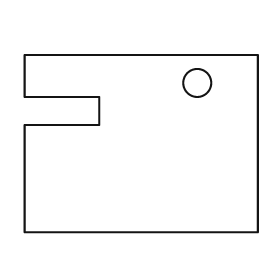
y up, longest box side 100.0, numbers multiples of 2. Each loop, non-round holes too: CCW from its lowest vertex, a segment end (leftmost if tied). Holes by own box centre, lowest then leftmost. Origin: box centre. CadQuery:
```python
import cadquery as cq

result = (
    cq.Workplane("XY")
    .moveTo(-50.0, -38.0)
    .lineTo(50.0, -38.0)
    .lineTo(50.0, 38.0)
    .lineTo(-50.0, 38.0)
    .lineTo(-50.0, 20.0)
    .lineTo(-18.0, 20.0)
    .lineTo(-18.0, 8.0)
    .lineTo(-50.0, 8.0)
    .close()
    .moveTo(24.0, 26.0)
    .circle(6.0)
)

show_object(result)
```